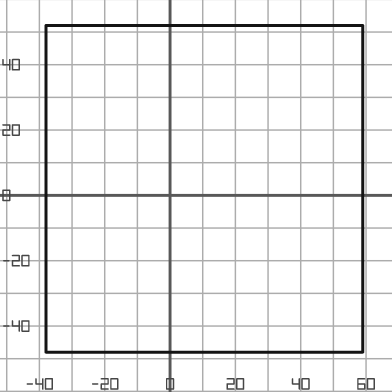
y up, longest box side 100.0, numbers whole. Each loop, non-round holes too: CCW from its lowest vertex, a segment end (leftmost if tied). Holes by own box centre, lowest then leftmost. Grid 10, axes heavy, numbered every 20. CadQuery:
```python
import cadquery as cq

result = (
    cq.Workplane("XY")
    .moveTo(-38.0, -48.0)
    .lineTo(59.0, -48.0)
    .lineTo(59.0, 52.0)
    .lineTo(-38.0, 52.0)
    .close()
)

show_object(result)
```